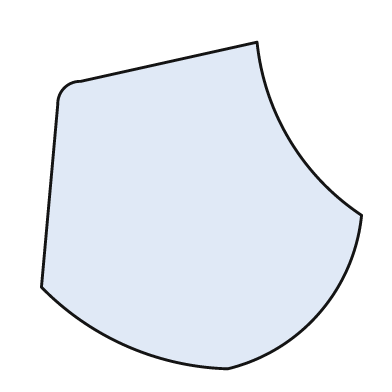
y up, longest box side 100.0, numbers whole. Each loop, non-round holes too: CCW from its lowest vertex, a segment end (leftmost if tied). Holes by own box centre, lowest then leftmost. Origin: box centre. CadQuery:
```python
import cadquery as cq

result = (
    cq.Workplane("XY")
    .moveTo(8.0, -50.0)
    .threePointArc((36.0, -33.0), (49.0, -3.0))
    .threePointArc((27.0, 20.0), (17.0, 50.0))
    .lineTo(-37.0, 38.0)
    .threePointArc((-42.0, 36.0), (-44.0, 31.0))
    .lineTo(-49.0, -25.0)
    .threePointArc((-23.0, -43.0), (8.0, -50.0))
    .close()
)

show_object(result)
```